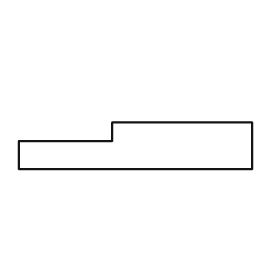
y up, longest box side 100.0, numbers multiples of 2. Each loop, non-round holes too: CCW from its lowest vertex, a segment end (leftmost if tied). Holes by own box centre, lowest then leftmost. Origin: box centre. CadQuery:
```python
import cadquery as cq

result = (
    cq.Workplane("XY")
    .moveTo(-50.0, -10.0)
    .lineTo(50.0, -10.0)
    .lineTo(50.0, 10.0)
    .lineTo(-10.0, 10.0)
    .lineTo(-10.0, 2.0)
    .lineTo(-50.0, 2.0)
    .close()
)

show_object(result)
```